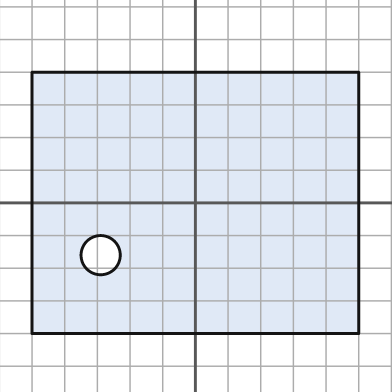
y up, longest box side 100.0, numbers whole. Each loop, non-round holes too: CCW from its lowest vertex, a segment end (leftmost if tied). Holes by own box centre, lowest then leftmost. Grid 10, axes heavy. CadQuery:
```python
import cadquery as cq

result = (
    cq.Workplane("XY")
    .moveTo(-50.0, -40.0)
    .lineTo(50.0, -40.0)
    .lineTo(50.0, 40.0)
    .lineTo(-50.0, 40.0)
    .close()
    .moveTo(-29.0, -16.0)
    .circle(6.0)
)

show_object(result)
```